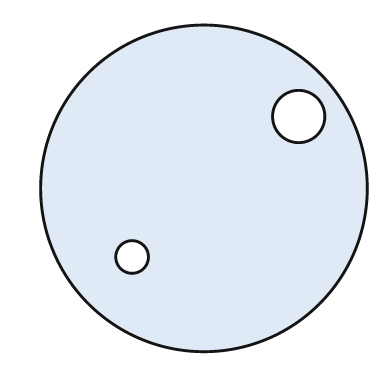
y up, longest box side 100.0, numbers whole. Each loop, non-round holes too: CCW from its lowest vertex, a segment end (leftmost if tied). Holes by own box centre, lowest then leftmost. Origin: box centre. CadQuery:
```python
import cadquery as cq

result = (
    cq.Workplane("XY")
    .moveTo(0.0, 0.0)
    .circle(50.0)
    .moveTo(-22.0, -21.0)
    .circle(5.0)
    .moveTo(29.0, 22.0)
    .circle(8.0)
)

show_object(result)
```